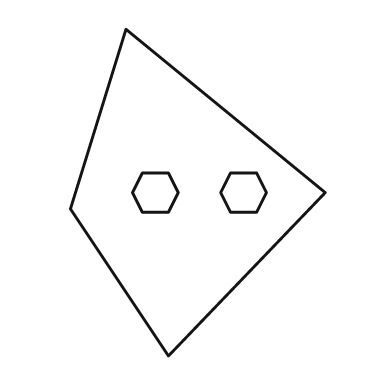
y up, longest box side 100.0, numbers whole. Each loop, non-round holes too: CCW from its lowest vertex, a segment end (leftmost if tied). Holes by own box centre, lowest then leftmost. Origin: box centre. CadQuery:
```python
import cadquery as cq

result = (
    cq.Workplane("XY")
    .moveTo(-9.0, -50.0)
    .lineTo(39.0, 0.0)
    .lineTo(-22.0, 50.0)
    .lineTo(-39.0, -5.0)
    .close()
    .moveTo(-17.0, -6.0)
    .lineTo(-9.0, -6.0)
    .lineTo(-6.0, 0.0)
    .lineTo(-9.0, 6.0)
    .lineTo(-17.0, 6.0)
    .lineTo(-20.0, 0.0)
    .close()
    .moveTo(10.0, -6.0)
    .lineTo(18.0, -6.0)
    .lineTo(21.0, 0.0)
    .lineTo(18.0, 6.0)
    .lineTo(10.0, 6.0)
    .lineTo(7.0, 0.0)
    .close()
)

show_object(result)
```